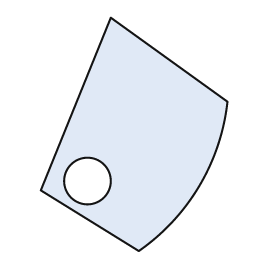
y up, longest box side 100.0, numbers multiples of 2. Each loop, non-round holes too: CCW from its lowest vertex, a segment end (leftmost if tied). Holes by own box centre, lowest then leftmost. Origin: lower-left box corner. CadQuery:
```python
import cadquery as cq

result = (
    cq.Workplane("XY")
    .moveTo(42.0, 0.0)
    .threePointArc((68.0, 28.0), (80.0, 64.0))
    .lineTo(30.0, 100.0)
    .lineTo(0.0, 26.0)
    .close()
    .moveTo(20.0, 30.0)
    .circle(10.0)
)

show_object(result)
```